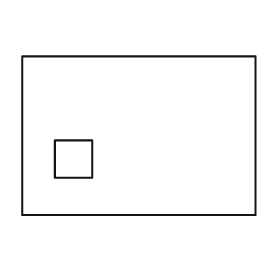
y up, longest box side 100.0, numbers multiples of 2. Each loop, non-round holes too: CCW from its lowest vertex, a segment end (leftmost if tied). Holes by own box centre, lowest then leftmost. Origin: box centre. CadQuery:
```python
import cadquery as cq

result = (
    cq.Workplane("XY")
    .moveTo(-50.0, -34.0)
    .lineTo(50.0, -34.0)
    .lineTo(50.0, 34.0)
    .lineTo(-50.0, 34.0)
    .close()
    .moveTo(-36.0, -18.0)
    .lineTo(-20.0, -18.0)
    .lineTo(-20.0, -2.0)
    .lineTo(-36.0, -2.0)
    .close()
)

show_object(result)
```